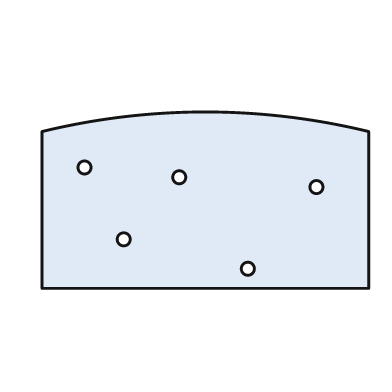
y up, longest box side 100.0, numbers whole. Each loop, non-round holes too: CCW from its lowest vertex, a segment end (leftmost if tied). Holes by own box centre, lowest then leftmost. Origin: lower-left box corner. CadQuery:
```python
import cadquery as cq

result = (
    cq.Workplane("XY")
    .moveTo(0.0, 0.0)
    .lineTo(100.0, 0.0)
    .lineTo(100.0, 48.0)
    .threePointArc((50.0, 54.0), (0.0, 48.0))
    .close()
    .moveTo(63.0, 6.0)
    .circle(2.0)
    .moveTo(25.0, 15.0)
    .circle(2.0)
    .moveTo(84.0, 31.0)
    .circle(2.0)
    .moveTo(42.0, 34.0)
    .circle(2.0)
    .moveTo(13.0, 37.0)
    .circle(2.0)
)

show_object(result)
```